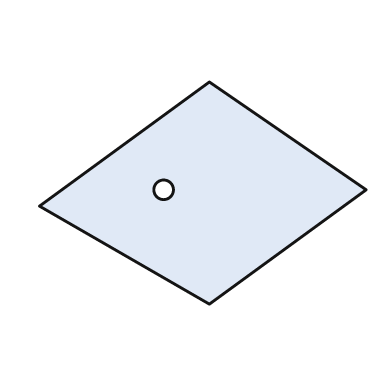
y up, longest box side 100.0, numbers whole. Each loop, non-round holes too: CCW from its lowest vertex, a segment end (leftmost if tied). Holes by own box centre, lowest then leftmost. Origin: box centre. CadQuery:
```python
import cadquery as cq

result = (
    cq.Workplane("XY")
    .moveTo(2.0, -34.0)
    .lineTo(50.0, 1.0)
    .lineTo(2.0, 34.0)
    .lineTo(-50.0, -4.0)
    .close()
    .moveTo(-12.0, 1.0)
    .circle(3.0)
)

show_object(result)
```